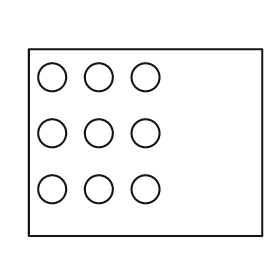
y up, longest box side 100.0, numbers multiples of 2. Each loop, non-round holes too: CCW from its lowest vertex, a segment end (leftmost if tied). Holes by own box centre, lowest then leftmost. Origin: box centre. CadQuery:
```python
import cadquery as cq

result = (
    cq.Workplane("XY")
    .moveTo(-50.0, -40.0)
    .lineTo(50.0, -40.0)
    .lineTo(50.0, 40.0)
    .lineTo(-50.0, 40.0)
    .close()
    .moveTo(-40.0, -20.0)
    .circle(6.0)
    .moveTo(-20.0, -20.0)
    .circle(6.0)
    .moveTo(0.0, -20.0)
    .circle(6.0)
    .moveTo(-40.0, 4.0)
    .circle(6.0)
    .moveTo(-20.0, 4.0)
    .circle(6.0)
    .moveTo(0.0, 4.0)
    .circle(6.0)
    .moveTo(-40.0, 28.0)
    .circle(6.0)
    .moveTo(-20.0, 28.0)
    .circle(6.0)
    .moveTo(0.0, 28.0)
    .circle(6.0)
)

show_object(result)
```